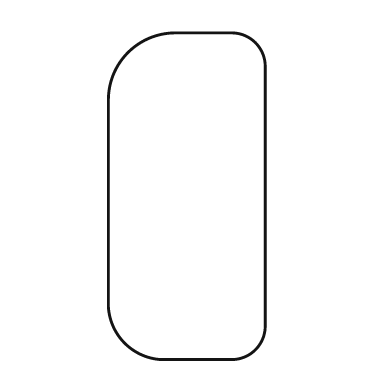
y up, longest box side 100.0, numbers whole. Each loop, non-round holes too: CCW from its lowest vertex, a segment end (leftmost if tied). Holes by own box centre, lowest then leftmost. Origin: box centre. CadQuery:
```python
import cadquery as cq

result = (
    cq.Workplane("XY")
    .moveTo(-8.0, -50.0)
    .lineTo(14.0, -50.0)
    .threePointArc((21.0, -47.0), (24.0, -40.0))
    .lineTo(24.0, 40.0)
    .threePointArc((21.0, 47.0), (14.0, 50.0))
    .lineTo(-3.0, 50.0)
    .threePointArc((-18.0, 44.0), (-24.0, 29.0))
    .lineTo(-24.0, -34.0)
    .threePointArc((-19.0, -45.0), (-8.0, -50.0))
    .close()
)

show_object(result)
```